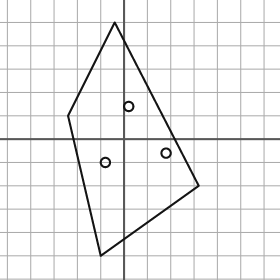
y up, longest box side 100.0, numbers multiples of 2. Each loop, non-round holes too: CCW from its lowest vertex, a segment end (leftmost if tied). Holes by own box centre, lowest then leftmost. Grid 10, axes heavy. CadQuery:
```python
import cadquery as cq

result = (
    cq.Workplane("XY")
    .moveTo(-10.0, -50.0)
    .lineTo(32.0, -20.0)
    .lineTo(-4.0, 50.0)
    .lineTo(-24.0, 10.0)
    .close()
    .moveTo(-8.0, -10.0)
    .circle(2.0)
    .moveTo(18.0, -6.0)
    .circle(2.0)
    .moveTo(2.0, 14.0)
    .circle(2.0)
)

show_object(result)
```